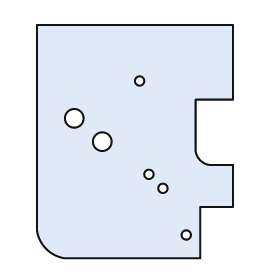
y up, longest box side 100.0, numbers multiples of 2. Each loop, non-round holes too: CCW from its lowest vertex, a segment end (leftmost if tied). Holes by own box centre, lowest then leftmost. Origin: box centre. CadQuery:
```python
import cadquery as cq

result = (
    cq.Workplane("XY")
    .moveTo(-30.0, -50.0)
    .lineTo(28.0, -50.0)
    .lineTo(28.0, -28.0)
    .lineTo(42.0, -28.0)
    .lineTo(42.0, -10.0)
    .lineTo(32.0, -10.0)
    .threePointArc((28.0, -8.0), (26.0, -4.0))
    .lineTo(26.0, 18.0)
    .lineTo(42.0, 18.0)
    .lineTo(42.0, 50.0)
    .lineTo(-42.0, 50.0)
    .lineTo(-42.0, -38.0)
    .threePointArc((-38.0, -46.0), (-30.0, -50.0))
    .close()
    .moveTo(22.0, -40.0)
    .circle(2.0)
    .moveTo(12.0, -20.0)
    .circle(2.0)
    .moveTo(6.0, -14.0)
    .circle(2.0)
    .moveTo(-14.0, 0.0)
    .circle(4.0)
    .moveTo(-26.0, 10.0)
    .circle(4.0)
    .moveTo(2.0, 26.0)
    .circle(2.0)
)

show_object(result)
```